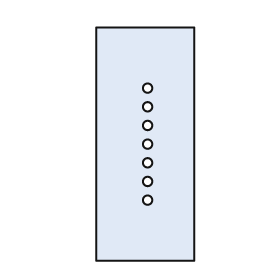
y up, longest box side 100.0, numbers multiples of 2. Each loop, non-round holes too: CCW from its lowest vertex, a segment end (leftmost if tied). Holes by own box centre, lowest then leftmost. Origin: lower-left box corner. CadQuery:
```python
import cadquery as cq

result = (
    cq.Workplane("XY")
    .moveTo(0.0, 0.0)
    .lineTo(42.0, 0.0)
    .lineTo(42.0, 100.0)
    .lineTo(0.0, 100.0)
    .close()
    .moveTo(22.0, 26.0)
    .circle(2.0)
    .moveTo(22.0, 34.0)
    .circle(2.0)
    .moveTo(22.0, 42.0)
    .circle(2.0)
    .moveTo(22.0, 50.0)
    .circle(2.0)
    .moveTo(22.0, 58.0)
    .circle(2.0)
    .moveTo(22.0, 66.0)
    .circle(2.0)
    .moveTo(22.0, 74.0)
    .circle(2.0)
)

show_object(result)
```